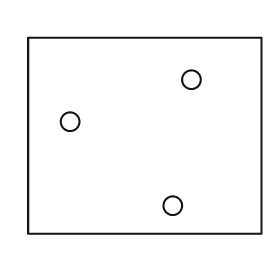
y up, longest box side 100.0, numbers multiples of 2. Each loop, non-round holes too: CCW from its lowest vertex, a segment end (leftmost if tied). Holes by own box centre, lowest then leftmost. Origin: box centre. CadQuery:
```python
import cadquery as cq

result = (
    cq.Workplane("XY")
    .moveTo(-50.0, -42.0)
    .lineTo(50.0, -42.0)
    .lineTo(50.0, 42.0)
    .lineTo(-50.0, 42.0)
    .close()
    .moveTo(12.0, -30.0)
    .circle(4.0)
    .moveTo(-32.0, 6.0)
    .circle(4.0)
    .moveTo(20.0, 24.0)
    .circle(4.0)
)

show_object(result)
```